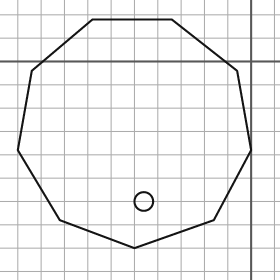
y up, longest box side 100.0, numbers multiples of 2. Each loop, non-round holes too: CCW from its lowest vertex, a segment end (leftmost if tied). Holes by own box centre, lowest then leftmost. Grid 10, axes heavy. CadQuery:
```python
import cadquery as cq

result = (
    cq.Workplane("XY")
    .moveTo(-50.0, -80.0)
    .lineTo(-16.0, -68.0)
    .lineTo(0.0, -38.0)
    .lineTo(-6.0, -4.0)
    .lineTo(-34.0, 18.0)
    .lineTo(-68.0, 18.0)
    .lineTo(-94.0, -4.0)
    .lineTo(-100.0, -38.0)
    .lineTo(-82.0, -68.0)
    .close()
    .moveTo(-46.0, -60.0)
    .circle(4.0)
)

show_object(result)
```